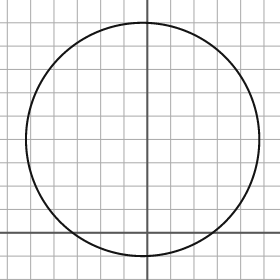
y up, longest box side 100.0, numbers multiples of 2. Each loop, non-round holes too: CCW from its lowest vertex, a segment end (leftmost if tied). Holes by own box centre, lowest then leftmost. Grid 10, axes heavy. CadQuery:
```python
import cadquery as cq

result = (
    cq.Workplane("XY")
    .moveTo(-2.0, 40.0)
    .circle(50.0)
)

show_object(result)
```